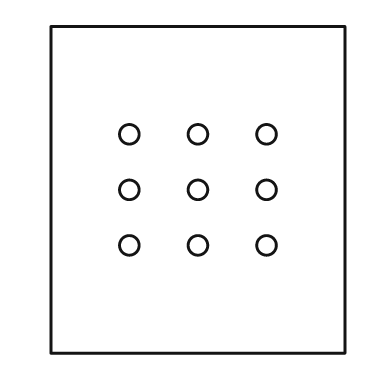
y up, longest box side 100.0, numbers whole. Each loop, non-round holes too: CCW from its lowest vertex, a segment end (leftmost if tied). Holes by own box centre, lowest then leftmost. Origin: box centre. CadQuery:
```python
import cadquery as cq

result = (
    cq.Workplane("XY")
    .moveTo(-45.0, -50.0)
    .lineTo(45.0, -50.0)
    .lineTo(45.0, 50.0)
    .lineTo(-45.0, 50.0)
    .close()
    .moveTo(-21.0, -17.0)
    .circle(3.0)
    .moveTo(0.0, -17.0)
    .circle(3.0)
    .moveTo(21.0, -17.0)
    .circle(3.0)
    .moveTo(-21.0, 0.0)
    .circle(3.0)
    .moveTo(0.0, 0.0)
    .circle(3.0)
    .moveTo(21.0, 0.0)
    .circle(3.0)
    .moveTo(-21.0, 17.0)
    .circle(3.0)
    .moveTo(0.0, 17.0)
    .circle(3.0)
    .moveTo(21.0, 17.0)
    .circle(3.0)
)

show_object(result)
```